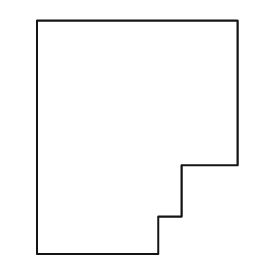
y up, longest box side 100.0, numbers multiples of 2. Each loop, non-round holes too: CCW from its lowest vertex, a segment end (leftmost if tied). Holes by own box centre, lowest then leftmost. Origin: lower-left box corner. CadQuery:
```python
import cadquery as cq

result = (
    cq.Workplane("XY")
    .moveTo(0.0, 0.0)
    .lineTo(52.0, 0.0)
    .lineTo(52.0, 16.0)
    .lineTo(62.0, 16.0)
    .lineTo(62.0, 38.0)
    .lineTo(86.0, 38.0)
    .lineTo(86.0, 100.0)
    .lineTo(0.0, 100.0)
    .close()
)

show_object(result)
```